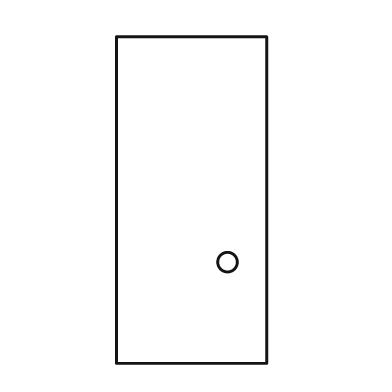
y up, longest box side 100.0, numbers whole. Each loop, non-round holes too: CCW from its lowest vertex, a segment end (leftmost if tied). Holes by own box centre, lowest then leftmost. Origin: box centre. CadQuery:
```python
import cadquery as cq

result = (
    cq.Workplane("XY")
    .moveTo(-23.0, -50.0)
    .lineTo(23.0, -50.0)
    .lineTo(23.0, 50.0)
    .lineTo(-23.0, 50.0)
    .close()
    .moveTo(11.0, -19.0)
    .circle(3.0)
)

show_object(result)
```